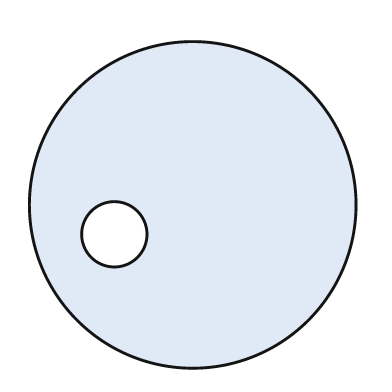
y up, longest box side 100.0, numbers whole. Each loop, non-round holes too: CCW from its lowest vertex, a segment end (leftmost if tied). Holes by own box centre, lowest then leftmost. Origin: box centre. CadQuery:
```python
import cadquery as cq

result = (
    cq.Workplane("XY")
    .moveTo(0.0, 0.0)
    .circle(50.0)
    .moveTo(-24.0, -9.0)
    .circle(10.0)
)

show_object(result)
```